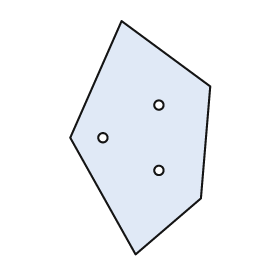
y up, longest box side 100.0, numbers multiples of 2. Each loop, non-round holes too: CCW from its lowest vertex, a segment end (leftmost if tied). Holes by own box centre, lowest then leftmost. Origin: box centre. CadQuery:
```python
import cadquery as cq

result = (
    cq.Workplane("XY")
    .moveTo(-2.0, -50.0)
    .lineTo(26.0, -26.0)
    .lineTo(30.0, 22.0)
    .lineTo(-8.0, 50.0)
    .lineTo(-30.0, 0.0)
    .close()
    .moveTo(8.0, -14.0)
    .circle(2.0)
    .moveTo(-16.0, 0.0)
    .circle(2.0)
    .moveTo(8.0, 14.0)
    .circle(2.0)
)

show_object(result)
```